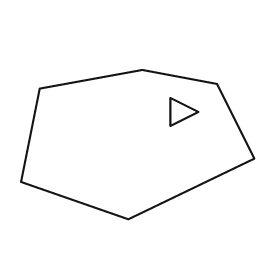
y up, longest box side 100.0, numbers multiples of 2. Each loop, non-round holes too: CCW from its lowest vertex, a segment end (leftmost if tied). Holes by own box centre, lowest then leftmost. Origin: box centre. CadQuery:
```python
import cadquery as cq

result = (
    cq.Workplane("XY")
    .moveTo(-4.0, -32.0)
    .lineTo(50.0, -6.0)
    .lineTo(34.0, 26.0)
    .lineTo(2.0, 32.0)
    .lineTo(-42.0, 24.0)
    .lineTo(-50.0, -16.0)
    .close()
    .moveTo(14.0, 8.0)
    .lineTo(26.0, 14.0)
    .lineTo(14.0, 20.0)
    .close()
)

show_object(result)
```